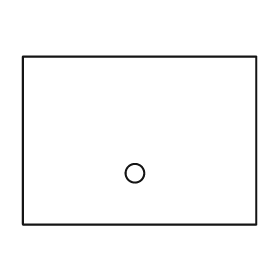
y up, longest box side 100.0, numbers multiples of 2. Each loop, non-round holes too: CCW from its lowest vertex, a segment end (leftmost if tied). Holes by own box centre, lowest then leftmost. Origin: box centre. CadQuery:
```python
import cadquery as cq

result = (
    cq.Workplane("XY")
    .moveTo(-50.0, -36.0)
    .lineTo(50.0, -36.0)
    .lineTo(50.0, 36.0)
    .lineTo(-50.0, 36.0)
    .close()
    .moveTo(-2.0, -14.0)
    .circle(4.0)
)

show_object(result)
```